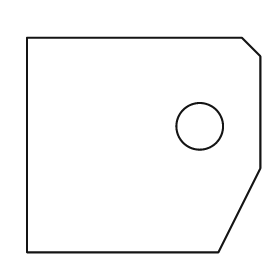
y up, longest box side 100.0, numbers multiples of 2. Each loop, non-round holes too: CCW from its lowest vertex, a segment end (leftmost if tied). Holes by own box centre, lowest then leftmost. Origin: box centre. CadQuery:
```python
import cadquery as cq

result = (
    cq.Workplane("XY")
    .moveTo(-50.0, -46.0)
    .lineTo(32.0, -46.0)
    .lineTo(50.0, -10.0)
    .lineTo(50.0, 38.0)
    .lineTo(42.0, 46.0)
    .lineTo(-50.0, 46.0)
    .close()
    .moveTo(24.0, 8.0)
    .circle(10.0)
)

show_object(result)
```